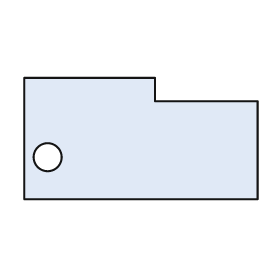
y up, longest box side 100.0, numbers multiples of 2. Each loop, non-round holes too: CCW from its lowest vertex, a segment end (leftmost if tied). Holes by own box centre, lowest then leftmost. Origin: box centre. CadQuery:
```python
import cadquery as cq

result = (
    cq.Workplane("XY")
    .moveTo(-50.0, -26.0)
    .lineTo(50.0, -26.0)
    .lineTo(50.0, 16.0)
    .lineTo(6.0, 16.0)
    .lineTo(6.0, 26.0)
    .lineTo(-50.0, 26.0)
    .close()
    .moveTo(-40.0, -8.0)
    .circle(6.0)
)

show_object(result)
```